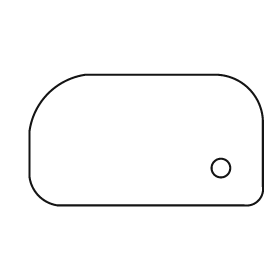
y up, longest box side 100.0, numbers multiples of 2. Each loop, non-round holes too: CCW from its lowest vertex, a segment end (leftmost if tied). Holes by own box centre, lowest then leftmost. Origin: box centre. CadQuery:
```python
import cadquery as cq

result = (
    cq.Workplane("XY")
    .moveTo(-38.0, -28.0)
    .lineTo(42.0, -28.0)
    .threePointArc((48.0, -26.0), (50.0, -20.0))
    .lineTo(50.0, 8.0)
    .threePointArc((44.0, 22.0), (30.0, 28.0))
    .lineTo(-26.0, 28.0)
    .threePointArc((-42.0, 20.0), (-50.0, 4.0))
    .lineTo(-50.0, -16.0)
    .threePointArc((-46.0, -24.0), (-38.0, -28.0))
    .close()
    .moveTo(32.0, -12.0)
    .circle(4.0)
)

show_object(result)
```